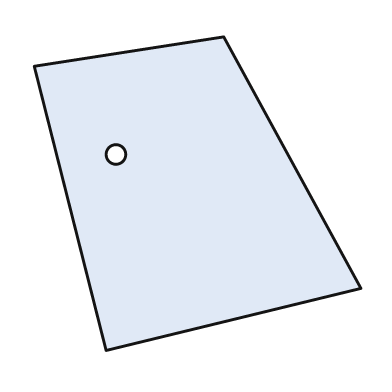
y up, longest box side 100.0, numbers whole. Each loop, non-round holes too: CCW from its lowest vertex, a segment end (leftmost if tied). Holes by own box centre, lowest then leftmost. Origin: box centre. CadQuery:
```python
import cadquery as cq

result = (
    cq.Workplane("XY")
    .moveTo(-28.0, -48.0)
    .lineTo(50.0, -29.0)
    .lineTo(8.0, 48.0)
    .lineTo(-50.0, 39.0)
    .close()
    .moveTo(-25.0, 12.0)
    .circle(3.0)
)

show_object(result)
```